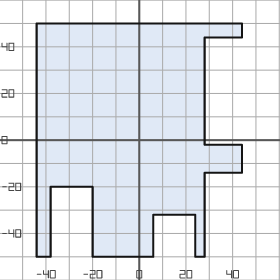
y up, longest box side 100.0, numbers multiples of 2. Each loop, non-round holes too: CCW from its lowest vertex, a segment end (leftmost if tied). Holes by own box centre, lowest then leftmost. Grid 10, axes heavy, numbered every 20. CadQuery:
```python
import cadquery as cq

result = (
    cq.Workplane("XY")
    .moveTo(-44.0, -50.0)
    .lineTo(-38.0, -50.0)
    .lineTo(-38.0, -20.0)
    .lineTo(-20.0, -20.0)
    .lineTo(-20.0, -50.0)
    .lineTo(6.0, -50.0)
    .lineTo(6.0, -32.0)
    .lineTo(24.0, -32.0)
    .lineTo(24.0, -50.0)
    .lineTo(28.0, -50.0)
    .lineTo(28.0, -14.0)
    .lineTo(44.0, -14.0)
    .lineTo(44.0, -2.0)
    .lineTo(28.0, -2.0)
    .lineTo(28.0, 44.0)
    .lineTo(44.0, 44.0)
    .lineTo(44.0, 50.0)
    .lineTo(-44.0, 50.0)
    .close()
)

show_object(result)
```